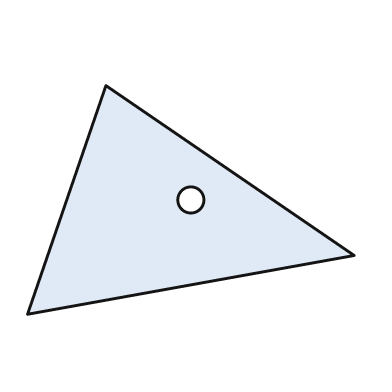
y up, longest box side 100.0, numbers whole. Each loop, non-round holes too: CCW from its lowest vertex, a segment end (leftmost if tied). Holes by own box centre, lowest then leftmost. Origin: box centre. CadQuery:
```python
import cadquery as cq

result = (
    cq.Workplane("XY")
    .moveTo(-50.0, -35.0)
    .lineTo(50.0, -17.0)
    .lineTo(-26.0, 35.0)
    .close()
    .moveTo(0.0, 0.0)
    .circle(4.0)
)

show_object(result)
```